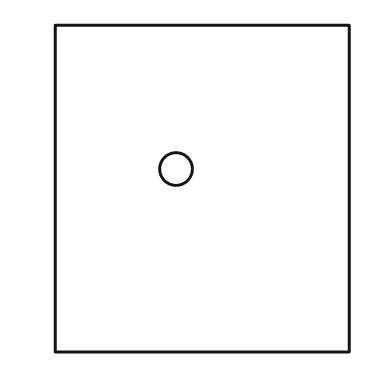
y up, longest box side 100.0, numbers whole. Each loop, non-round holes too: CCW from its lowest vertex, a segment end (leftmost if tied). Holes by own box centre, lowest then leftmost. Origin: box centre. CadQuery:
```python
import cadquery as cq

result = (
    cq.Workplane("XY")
    .moveTo(-45.0, -50.0)
    .lineTo(45.0, -50.0)
    .lineTo(45.0, 50.0)
    .lineTo(-45.0, 50.0)
    .close()
    .moveTo(-8.0, 6.0)
    .circle(5.0)
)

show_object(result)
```